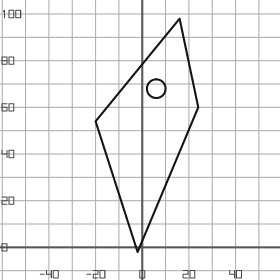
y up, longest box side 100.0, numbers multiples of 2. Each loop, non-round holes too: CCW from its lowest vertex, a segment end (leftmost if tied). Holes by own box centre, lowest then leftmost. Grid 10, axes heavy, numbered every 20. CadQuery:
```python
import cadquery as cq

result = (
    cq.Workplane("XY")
    .moveTo(-2.0, -2.0)
    .lineTo(24.0, 60.0)
    .lineTo(16.0, 98.0)
    .lineTo(-20.0, 54.0)
    .close()
    .moveTo(6.0, 68.0)
    .circle(4.0)
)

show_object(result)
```